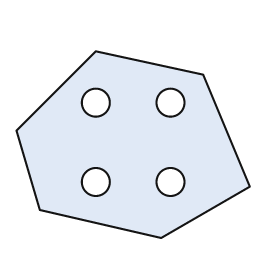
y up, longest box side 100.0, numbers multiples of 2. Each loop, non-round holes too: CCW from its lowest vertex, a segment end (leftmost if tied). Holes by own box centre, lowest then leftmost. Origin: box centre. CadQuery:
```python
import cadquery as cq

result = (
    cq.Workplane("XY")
    .moveTo(12.0, -40.0)
    .lineTo(50.0, -18.0)
    .lineTo(30.0, 30.0)
    .lineTo(-16.0, 40.0)
    .lineTo(-50.0, 6.0)
    .lineTo(-40.0, -28.0)
    .close()
    .moveTo(-16.0, -16.0)
    .circle(6.0)
    .moveTo(16.0, -16.0)
    .circle(6.0)
    .moveTo(-16.0, 18.0)
    .circle(6.0)
    .moveTo(16.0, 18.0)
    .circle(6.0)
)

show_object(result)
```